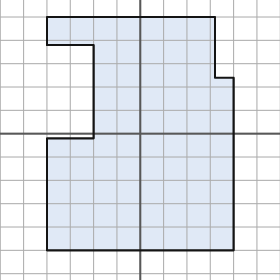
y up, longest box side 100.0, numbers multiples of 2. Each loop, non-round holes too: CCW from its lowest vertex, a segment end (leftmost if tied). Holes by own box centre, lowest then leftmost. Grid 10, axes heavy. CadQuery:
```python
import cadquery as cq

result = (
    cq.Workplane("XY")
    .moveTo(-40.0, -50.0)
    .lineTo(40.0, -50.0)
    .lineTo(40.0, 24.0)
    .lineTo(32.0, 24.0)
    .lineTo(32.0, 50.0)
    .lineTo(-40.0, 50.0)
    .lineTo(-40.0, 38.0)
    .lineTo(-20.0, 38.0)
    .lineTo(-20.0, -2.0)
    .lineTo(-40.0, -2.0)
    .close()
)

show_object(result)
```